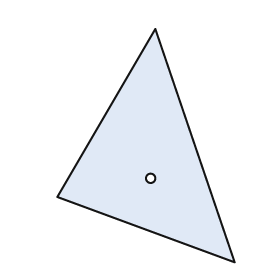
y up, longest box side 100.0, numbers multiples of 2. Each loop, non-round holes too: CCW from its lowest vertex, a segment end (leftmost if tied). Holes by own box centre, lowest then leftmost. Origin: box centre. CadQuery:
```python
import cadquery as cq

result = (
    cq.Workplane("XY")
    .moveTo(38.0, -50.0)
    .lineTo(4.0, 50.0)
    .lineTo(-38.0, -22.0)
    .close()
    .moveTo(2.0, -14.0)
    .circle(2.0)
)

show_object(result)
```